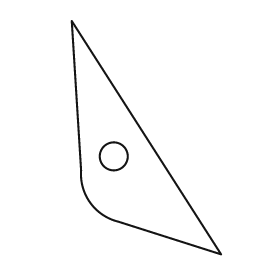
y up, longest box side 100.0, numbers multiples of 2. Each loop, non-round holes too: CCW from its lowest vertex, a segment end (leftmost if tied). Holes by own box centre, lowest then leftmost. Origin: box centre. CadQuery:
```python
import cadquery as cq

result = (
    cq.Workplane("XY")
    .moveTo(32.0, -50.0)
    .lineTo(-32.0, 50.0)
    .lineTo(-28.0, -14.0)
    .threePointArc((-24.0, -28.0), (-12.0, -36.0))
    .close()
    .moveTo(-14.0, -8.0)
    .circle(6.0)
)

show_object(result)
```